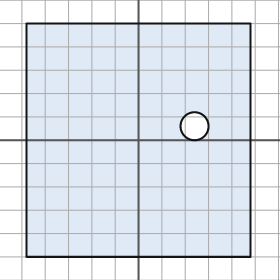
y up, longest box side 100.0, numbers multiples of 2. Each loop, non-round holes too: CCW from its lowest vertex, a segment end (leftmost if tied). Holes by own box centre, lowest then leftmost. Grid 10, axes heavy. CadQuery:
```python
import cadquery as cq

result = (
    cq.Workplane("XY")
    .moveTo(-48.0, -50.0)
    .lineTo(48.0, -50.0)
    .lineTo(48.0, 50.0)
    .lineTo(-48.0, 50.0)
    .close()
    .moveTo(24.0, 6.0)
    .circle(6.0)
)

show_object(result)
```